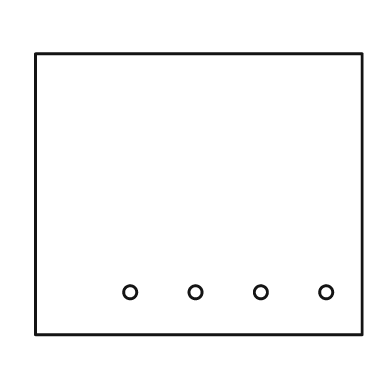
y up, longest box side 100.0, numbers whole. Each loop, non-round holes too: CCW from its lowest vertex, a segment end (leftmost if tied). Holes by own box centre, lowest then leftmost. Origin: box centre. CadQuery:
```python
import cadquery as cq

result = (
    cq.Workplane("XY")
    .moveTo(-50.0, -43.0)
    .lineTo(50.0, -43.0)
    .lineTo(50.0, 43.0)
    .lineTo(-50.0, 43.0)
    .close()
    .moveTo(-21.0, -30.0)
    .circle(2.0)
    .moveTo(-1.0, -30.0)
    .circle(2.0)
    .moveTo(19.0, -30.0)
    .circle(2.0)
    .moveTo(39.0, -30.0)
    .circle(2.0)
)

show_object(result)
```